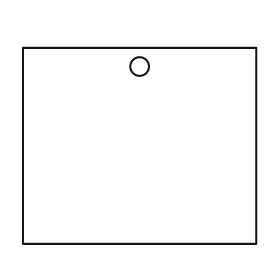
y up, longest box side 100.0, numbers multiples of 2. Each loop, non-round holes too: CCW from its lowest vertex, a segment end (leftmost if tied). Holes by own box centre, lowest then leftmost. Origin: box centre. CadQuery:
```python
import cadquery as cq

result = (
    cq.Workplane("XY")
    .moveTo(-50.0, -42.0)
    .lineTo(50.0, -42.0)
    .lineTo(50.0, 42.0)
    .lineTo(-50.0, 42.0)
    .close()
    .moveTo(0.0, 34.0)
    .circle(4.0)
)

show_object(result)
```